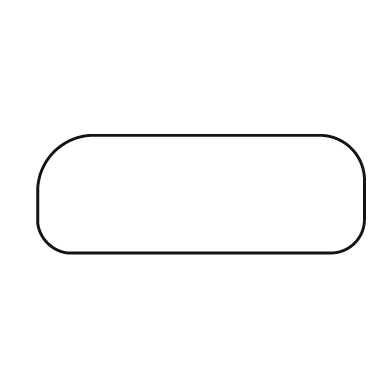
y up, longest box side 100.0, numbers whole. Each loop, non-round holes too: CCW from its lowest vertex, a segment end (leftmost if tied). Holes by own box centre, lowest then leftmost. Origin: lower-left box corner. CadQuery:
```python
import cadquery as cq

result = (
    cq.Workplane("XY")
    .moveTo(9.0, 0.0)
    .lineTo(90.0, 0.0)
    .threePointArc((97.0, 3.0), (100.0, 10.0))
    .lineTo(100.0, 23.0)
    .threePointArc((96.0, 32.0), (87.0, 36.0))
    .lineTo(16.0, 36.0)
    .threePointArc((5.0, 31.0), (0.0, 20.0))
    .lineTo(0.0, 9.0)
    .threePointArc((3.0, 3.0), (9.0, 0.0))
    .close()
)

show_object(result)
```